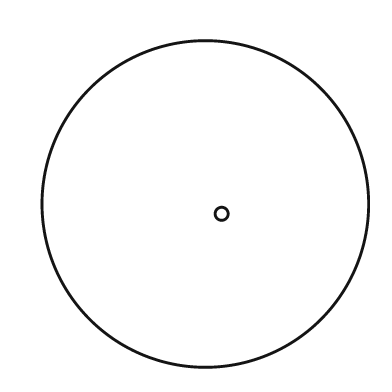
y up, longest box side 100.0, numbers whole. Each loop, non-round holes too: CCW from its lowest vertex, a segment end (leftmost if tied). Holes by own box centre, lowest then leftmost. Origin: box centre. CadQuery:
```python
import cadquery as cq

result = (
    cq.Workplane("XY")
    .moveTo(0.0, 0.0)
    .circle(50.0)
    .moveTo(5.0, -3.0)
    .circle(2.0)
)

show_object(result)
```